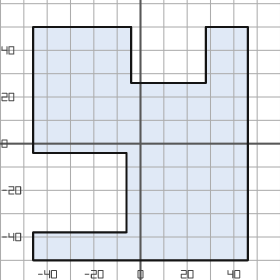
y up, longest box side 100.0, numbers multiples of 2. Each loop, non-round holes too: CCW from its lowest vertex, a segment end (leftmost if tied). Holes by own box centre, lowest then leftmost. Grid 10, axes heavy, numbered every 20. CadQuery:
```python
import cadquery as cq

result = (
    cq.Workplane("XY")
    .moveTo(-46.0, -50.0)
    .lineTo(46.0, -50.0)
    .lineTo(46.0, 50.0)
    .lineTo(28.0, 50.0)
    .lineTo(28.0, 26.0)
    .lineTo(-4.0, 26.0)
    .lineTo(-4.0, 50.0)
    .lineTo(-46.0, 50.0)
    .lineTo(-46.0, -4.0)
    .lineTo(-6.0, -4.0)
    .lineTo(-6.0, -38.0)
    .lineTo(-46.0, -38.0)
    .close()
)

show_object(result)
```